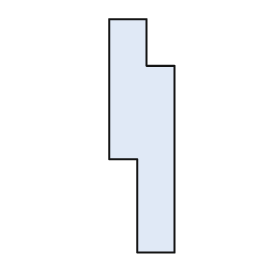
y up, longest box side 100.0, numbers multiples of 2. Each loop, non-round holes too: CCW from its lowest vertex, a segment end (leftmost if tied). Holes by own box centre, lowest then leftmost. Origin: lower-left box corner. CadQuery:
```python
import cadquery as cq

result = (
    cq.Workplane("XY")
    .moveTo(12.0, 0.0)
    .lineTo(28.0, 0.0)
    .lineTo(28.0, 80.0)
    .lineTo(16.0, 80.0)
    .lineTo(16.0, 100.0)
    .lineTo(0.0, 100.0)
    .lineTo(0.0, 40.0)
    .lineTo(12.0, 40.0)
    .close()
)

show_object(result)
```